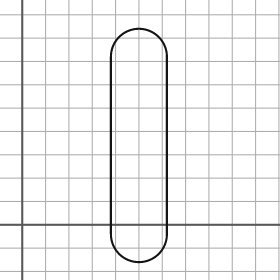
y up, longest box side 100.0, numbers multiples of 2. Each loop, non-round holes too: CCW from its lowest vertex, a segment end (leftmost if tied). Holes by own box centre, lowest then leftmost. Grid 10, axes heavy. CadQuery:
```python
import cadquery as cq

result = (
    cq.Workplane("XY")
    .moveTo(38.0, -4.0)
    .threePointArc((50.0, -16.0), (62.0, -4.0))
    .lineTo(62.0, 72.0)
    .threePointArc((50.0, 84.0), (38.0, 72.0))
    .close()
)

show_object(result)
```